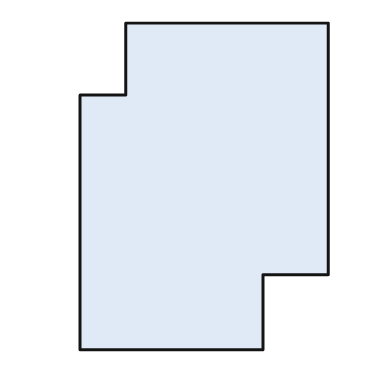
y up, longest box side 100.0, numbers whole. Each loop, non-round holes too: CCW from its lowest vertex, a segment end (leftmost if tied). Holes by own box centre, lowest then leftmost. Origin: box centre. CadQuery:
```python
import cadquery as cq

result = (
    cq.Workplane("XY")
    .moveTo(-38.0, -50.0)
    .lineTo(18.0, -50.0)
    .lineTo(18.0, -27.0)
    .lineTo(38.0, -27.0)
    .lineTo(38.0, 50.0)
    .lineTo(-24.0, 50.0)
    .lineTo(-24.0, 28.0)
    .lineTo(-38.0, 28.0)
    .close()
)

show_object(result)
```